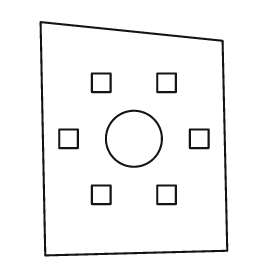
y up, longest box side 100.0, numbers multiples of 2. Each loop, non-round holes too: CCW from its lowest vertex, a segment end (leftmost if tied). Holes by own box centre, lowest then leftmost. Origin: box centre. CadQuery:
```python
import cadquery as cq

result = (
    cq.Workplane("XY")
    .moveTo(-38.0, -50.0)
    .lineTo(40.0, -48.0)
    .lineTo(38.0, 42.0)
    .lineTo(-40.0, 50.0)
    .close()
    .moveTo(-18.0, -28.0)
    .lineTo(-10.0, -28.0)
    .lineTo(-10.0, -20.0)
    .lineTo(-18.0, -20.0)
    .close()
    .moveTo(10.0, -28.0)
    .lineTo(18.0, -28.0)
    .lineTo(18.0, -20.0)
    .lineTo(10.0, -20.0)
    .close()
    .moveTo(-32.0, -4.0)
    .lineTo(-24.0, -4.0)
    .lineTo(-24.0, 4.0)
    .lineTo(-32.0, 4.0)
    .close()
    .moveTo(0.0, 0.0)
    .circle(12.0)
    .moveTo(24.0, -4.0)
    .lineTo(32.0, -4.0)
    .lineTo(32.0, 4.0)
    .lineTo(24.0, 4.0)
    .close()
    .moveTo(-18.0, 20.0)
    .lineTo(-10.0, 20.0)
    .lineTo(-10.0, 28.0)
    .lineTo(-18.0, 28.0)
    .close()
    .moveTo(10.0, 20.0)
    .lineTo(18.0, 20.0)
    .lineTo(18.0, 28.0)
    .lineTo(10.0, 28.0)
    .close()
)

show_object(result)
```